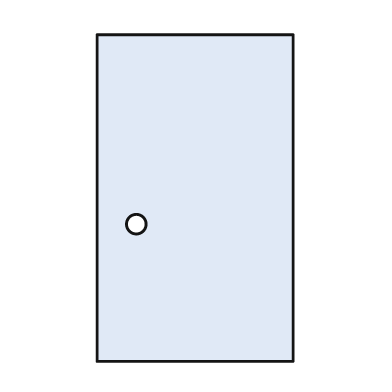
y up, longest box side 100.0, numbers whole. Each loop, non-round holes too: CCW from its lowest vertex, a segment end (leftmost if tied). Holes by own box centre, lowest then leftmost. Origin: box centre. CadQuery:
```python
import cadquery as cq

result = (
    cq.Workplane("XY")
    .moveTo(-30.0, -50.0)
    .lineTo(30.0, -50.0)
    .lineTo(30.0, 50.0)
    .lineTo(-30.0, 50.0)
    .close()
    .moveTo(-18.0, -8.0)
    .circle(3.0)
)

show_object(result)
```